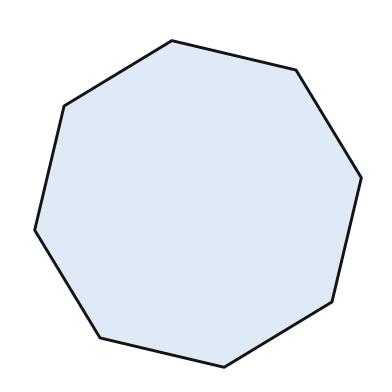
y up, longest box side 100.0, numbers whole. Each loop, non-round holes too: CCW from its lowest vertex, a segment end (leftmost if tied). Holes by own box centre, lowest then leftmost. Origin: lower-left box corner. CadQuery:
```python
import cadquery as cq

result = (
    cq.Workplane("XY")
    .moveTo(58.0, 0.0)
    .lineTo(91.0, 20.0)
    .lineTo(100.0, 58.0)
    .lineTo(80.0, 91.0)
    .lineTo(42.0, 100.0)
    .lineTo(9.0, 80.0)
    .lineTo(0.0, 42.0)
    .lineTo(20.0, 9.0)
    .close()
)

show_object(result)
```